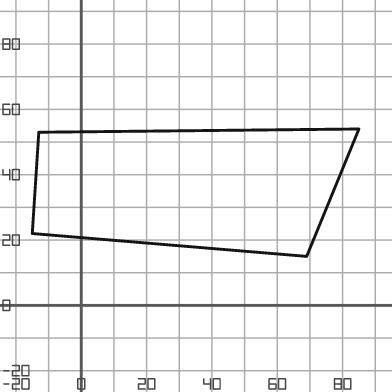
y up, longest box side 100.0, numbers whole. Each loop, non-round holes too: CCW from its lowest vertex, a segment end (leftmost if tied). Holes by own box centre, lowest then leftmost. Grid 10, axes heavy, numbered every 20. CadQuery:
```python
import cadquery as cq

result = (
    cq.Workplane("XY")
    .moveTo(69.0, 15.0)
    .lineTo(85.0, 54.0)
    .lineTo(-13.0, 53.0)
    .lineTo(-15.0, 22.0)
    .close()
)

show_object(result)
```